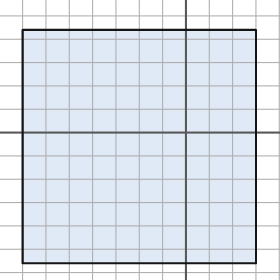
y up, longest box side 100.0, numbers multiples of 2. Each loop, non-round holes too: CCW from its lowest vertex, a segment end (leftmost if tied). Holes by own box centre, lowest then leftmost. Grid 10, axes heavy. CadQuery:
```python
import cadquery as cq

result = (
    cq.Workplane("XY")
    .moveTo(-70.0, -56.0)
    .lineTo(30.0, -56.0)
    .lineTo(30.0, 44.0)
    .lineTo(-70.0, 44.0)
    .close()
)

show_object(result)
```